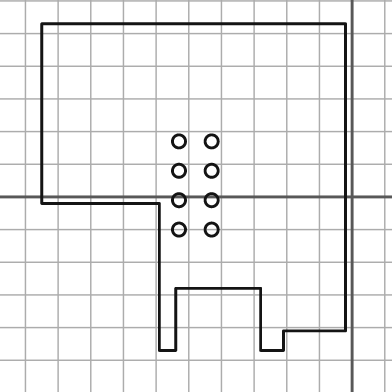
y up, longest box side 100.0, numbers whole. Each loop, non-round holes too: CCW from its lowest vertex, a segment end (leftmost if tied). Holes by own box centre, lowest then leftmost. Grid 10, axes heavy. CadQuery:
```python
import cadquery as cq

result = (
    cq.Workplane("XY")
    .moveTo(-59.0, -47.0)
    .lineTo(-54.0, -47.0)
    .lineTo(-54.0, -28.0)
    .lineTo(-28.0, -28.0)
    .lineTo(-28.0, -47.0)
    .lineTo(-21.0, -47.0)
    .lineTo(-21.0, -41.0)
    .lineTo(-2.0, -41.0)
    .lineTo(-2.0, 53.0)
    .lineTo(-95.0, 53.0)
    .lineTo(-95.0, -2.0)
    .lineTo(-59.0, -2.0)
    .close()
    .moveTo(-53.0, -10.0)
    .circle(2.0)
    .moveTo(-43.0, -10.0)
    .circle(2.0)
    .moveTo(-53.0, -1.0)
    .circle(2.0)
    .moveTo(-43.0, -1.0)
    .circle(2.0)
    .moveTo(-53.0, 8.0)
    .circle(2.0)
    .moveTo(-43.0, 8.0)
    .circle(2.0)
    .moveTo(-53.0, 17.0)
    .circle(2.0)
    .moveTo(-43.0, 17.0)
    .circle(2.0)
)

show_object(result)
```